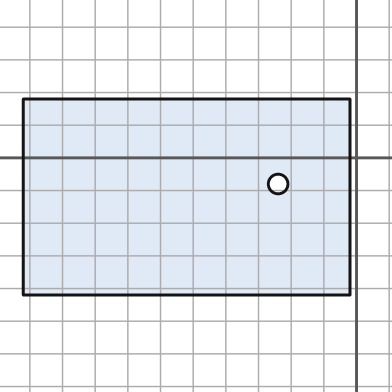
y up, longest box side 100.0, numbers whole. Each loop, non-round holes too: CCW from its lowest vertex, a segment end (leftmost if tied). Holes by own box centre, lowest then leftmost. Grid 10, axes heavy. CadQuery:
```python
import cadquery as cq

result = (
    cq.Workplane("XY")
    .moveTo(-102.0, -42.0)
    .lineTo(-2.0, -42.0)
    .lineTo(-2.0, 18.0)
    .lineTo(-102.0, 18.0)
    .close()
    .moveTo(-24.0, -8.0)
    .circle(3.0)
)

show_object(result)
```